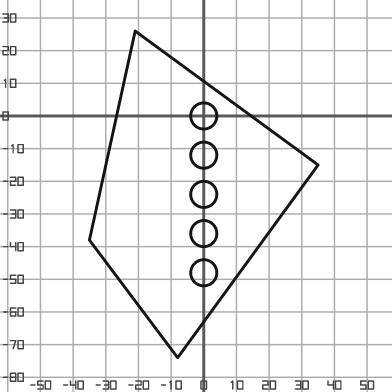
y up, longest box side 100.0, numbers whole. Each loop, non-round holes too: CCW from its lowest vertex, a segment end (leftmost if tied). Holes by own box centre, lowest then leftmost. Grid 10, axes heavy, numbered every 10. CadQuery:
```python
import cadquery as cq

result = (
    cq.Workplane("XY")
    .moveTo(-8.0, -74.0)
    .lineTo(35.0, -15.0)
    .lineTo(-21.0, 26.0)
    .lineTo(-35.0, -38.0)
    .close()
    .moveTo(0.0, -48.0)
    .circle(4.0)
    .moveTo(0.0, -36.0)
    .circle(4.0)
    .moveTo(0.0, -24.0)
    .circle(4.0)
    .moveTo(0.0, -12.0)
    .circle(4.0)
    .moveTo(0.0, 0.0)
    .circle(4.0)
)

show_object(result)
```